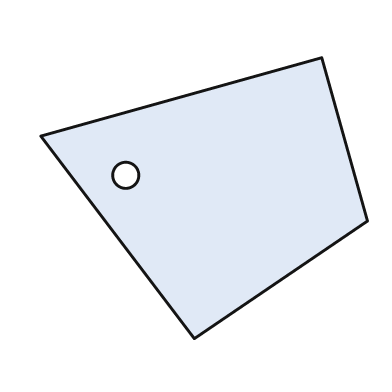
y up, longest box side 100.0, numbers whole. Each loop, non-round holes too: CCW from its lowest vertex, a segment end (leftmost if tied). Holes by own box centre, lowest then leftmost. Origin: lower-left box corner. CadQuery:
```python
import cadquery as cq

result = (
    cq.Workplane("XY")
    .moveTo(47.0, 0.0)
    .lineTo(100.0, 36.0)
    .lineTo(86.0, 86.0)
    .lineTo(0.0, 62.0)
    .close()
    .moveTo(26.0, 50.0)
    .circle(4.0)
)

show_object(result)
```